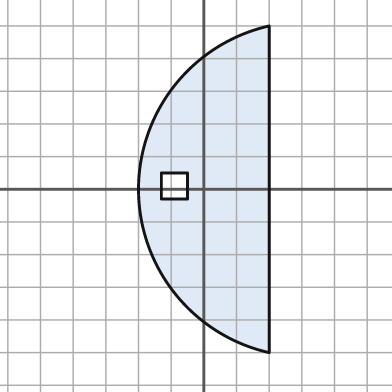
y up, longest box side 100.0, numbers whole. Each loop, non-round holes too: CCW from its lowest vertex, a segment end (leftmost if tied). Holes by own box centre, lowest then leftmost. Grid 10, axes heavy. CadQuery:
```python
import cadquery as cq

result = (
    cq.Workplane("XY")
    .moveTo(20.0, -50.0)
    .lineTo(20.0, 50.0)
    .threePointArc((-20.0, 0.0), (20.0, -50.0))
    .close()
    .moveTo(-13.0, -3.0)
    .lineTo(-5.0, -3.0)
    .lineTo(-5.0, 5.0)
    .lineTo(-13.0, 5.0)
    .close()
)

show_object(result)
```